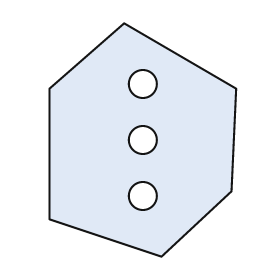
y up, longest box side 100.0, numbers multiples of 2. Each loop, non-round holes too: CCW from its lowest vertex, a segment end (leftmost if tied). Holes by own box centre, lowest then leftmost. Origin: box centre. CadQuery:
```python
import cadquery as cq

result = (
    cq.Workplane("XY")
    .moveTo(8.0, -50.0)
    .lineTo(38.0, -22.0)
    .lineTo(40.0, 22.0)
    .lineTo(-8.0, 50.0)
    .lineTo(-40.0, 22.0)
    .lineTo(-40.0, -34.0)
    .close()
    .moveTo(0.0, -24.0)
    .circle(6.0)
    .moveTo(0.0, 0.0)
    .circle(6.0)
    .moveTo(0.0, 24.0)
    .circle(6.0)
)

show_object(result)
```